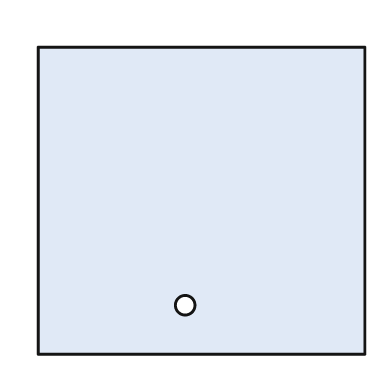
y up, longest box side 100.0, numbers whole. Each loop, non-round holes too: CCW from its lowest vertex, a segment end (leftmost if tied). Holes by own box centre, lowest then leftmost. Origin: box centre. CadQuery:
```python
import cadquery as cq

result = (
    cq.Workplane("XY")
    .moveTo(-50.0, -47.0)
    .lineTo(50.0, -47.0)
    .lineTo(50.0, 47.0)
    .lineTo(-50.0, 47.0)
    .close()
    .moveTo(-5.0, -32.0)
    .circle(3.0)
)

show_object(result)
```